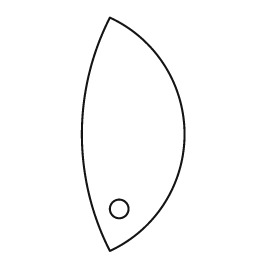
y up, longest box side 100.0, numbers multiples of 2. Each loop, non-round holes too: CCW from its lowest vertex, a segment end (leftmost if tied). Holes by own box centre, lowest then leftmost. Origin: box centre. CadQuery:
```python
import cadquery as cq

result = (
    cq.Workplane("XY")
    .moveTo(-10.0, -50.0)
    .threePointArc((22.0, 0.0), (-10.0, 50.0))
    .threePointArc((-22.0, 0.0), (-10.0, -50.0))
    .close()
    .moveTo(-6.0, -32.0)
    .circle(4.0)
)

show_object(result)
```